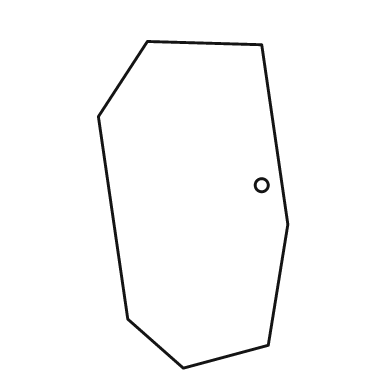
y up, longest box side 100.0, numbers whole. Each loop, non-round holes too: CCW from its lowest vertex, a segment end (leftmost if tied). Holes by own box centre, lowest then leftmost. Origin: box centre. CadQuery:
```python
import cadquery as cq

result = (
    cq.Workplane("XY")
    .moveTo(-3.0, -50.0)
    .lineTo(23.0, -43.0)
    .lineTo(29.0, -6.0)
    .lineTo(21.0, 49.0)
    .lineTo(-14.0, 50.0)
    .lineTo(-29.0, 27.0)
    .lineTo(-20.0, -35.0)
    .close()
    .moveTo(21.0, 6.0)
    .circle(2.0)
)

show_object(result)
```